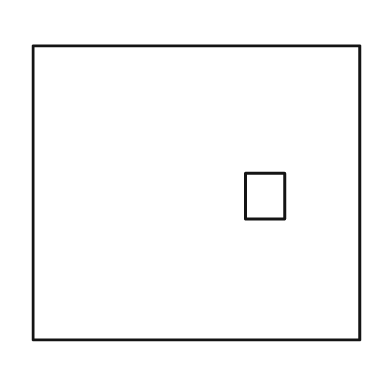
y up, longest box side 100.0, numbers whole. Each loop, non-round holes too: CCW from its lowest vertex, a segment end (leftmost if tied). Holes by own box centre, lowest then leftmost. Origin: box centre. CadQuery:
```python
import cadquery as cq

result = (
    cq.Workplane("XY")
    .moveTo(-50.0, -45.0)
    .lineTo(50.0, -45.0)
    .lineTo(50.0, 45.0)
    .lineTo(-50.0, 45.0)
    .close()
    .moveTo(15.0, -8.0)
    .lineTo(27.0, -8.0)
    .lineTo(27.0, 6.0)
    .lineTo(15.0, 6.0)
    .close()
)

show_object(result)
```